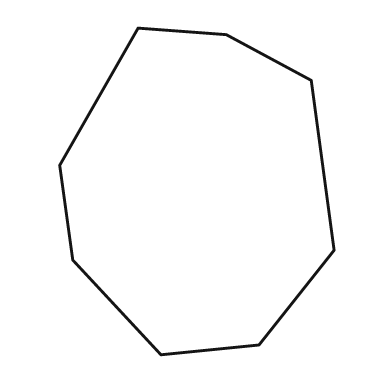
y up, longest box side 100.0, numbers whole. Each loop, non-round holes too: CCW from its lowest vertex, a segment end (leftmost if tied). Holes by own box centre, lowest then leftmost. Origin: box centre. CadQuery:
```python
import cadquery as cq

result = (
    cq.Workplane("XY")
    .moveTo(-11.0, -50.0)
    .lineTo(19.0, -47.0)
    .lineTo(42.0, -18.0)
    .lineTo(35.0, 34.0)
    .lineTo(9.0, 48.0)
    .lineTo(-18.0, 50.0)
    .lineTo(-42.0, 8.0)
    .lineTo(-38.0, -21.0)
    .close()
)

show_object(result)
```